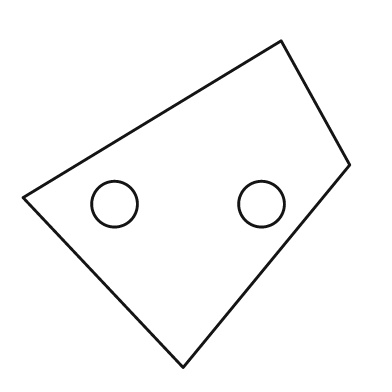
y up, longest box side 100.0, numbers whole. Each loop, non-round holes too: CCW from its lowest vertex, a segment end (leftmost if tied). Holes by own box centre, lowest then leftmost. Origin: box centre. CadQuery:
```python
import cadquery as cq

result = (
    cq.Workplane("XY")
    .moveTo(-1.0, -50.0)
    .lineTo(50.0, 12.0)
    .lineTo(29.0, 50.0)
    .lineTo(-50.0, 2.0)
    .close()
    .moveTo(-22.0, 0.0)
    .circle(7.0)
    .moveTo(23.0, 0.0)
    .circle(7.0)
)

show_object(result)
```